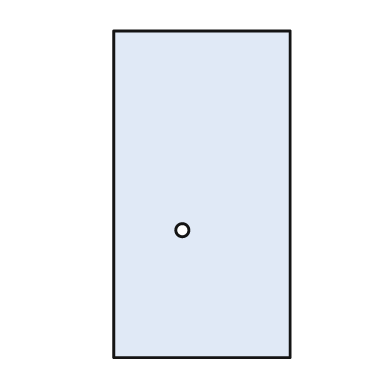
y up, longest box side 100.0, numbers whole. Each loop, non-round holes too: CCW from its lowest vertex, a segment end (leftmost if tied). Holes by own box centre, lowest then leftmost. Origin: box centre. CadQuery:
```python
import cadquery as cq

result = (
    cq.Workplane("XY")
    .moveTo(-27.0, -50.0)
    .lineTo(27.0, -50.0)
    .lineTo(27.0, 50.0)
    .lineTo(-27.0, 50.0)
    .close()
    .moveTo(-6.0, -11.0)
    .circle(2.0)
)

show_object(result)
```